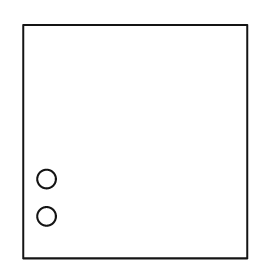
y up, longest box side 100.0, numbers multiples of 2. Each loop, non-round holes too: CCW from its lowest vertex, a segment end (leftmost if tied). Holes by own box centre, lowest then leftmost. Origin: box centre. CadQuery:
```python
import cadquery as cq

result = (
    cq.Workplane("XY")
    .moveTo(-48.0, -50.0)
    .lineTo(48.0, -50.0)
    .lineTo(48.0, 50.0)
    .lineTo(-48.0, 50.0)
    .close()
    .moveTo(-38.0, -32.0)
    .circle(4.0)
    .moveTo(-38.0, -16.0)
    .circle(4.0)
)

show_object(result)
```